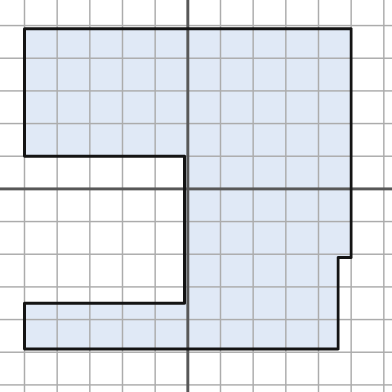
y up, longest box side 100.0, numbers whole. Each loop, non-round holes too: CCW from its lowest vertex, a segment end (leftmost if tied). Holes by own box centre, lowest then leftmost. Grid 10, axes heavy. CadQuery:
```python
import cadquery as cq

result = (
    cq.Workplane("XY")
    .moveTo(-50.0, -49.0)
    .lineTo(46.0, -49.0)
    .lineTo(46.0, -21.0)
    .lineTo(50.0, -21.0)
    .lineTo(50.0, 49.0)
    .lineTo(-50.0, 49.0)
    .lineTo(-50.0, 10.0)
    .lineTo(-1.0, 10.0)
    .lineTo(-1.0, -35.0)
    .lineTo(-50.0, -35.0)
    .close()
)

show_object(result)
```